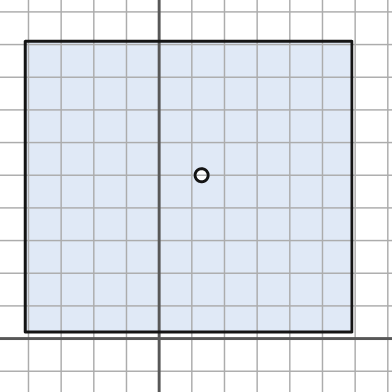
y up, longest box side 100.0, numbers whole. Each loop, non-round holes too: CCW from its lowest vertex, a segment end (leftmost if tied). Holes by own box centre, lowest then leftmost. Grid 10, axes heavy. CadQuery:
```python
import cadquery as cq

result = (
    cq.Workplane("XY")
    .moveTo(-41.0, 2.0)
    .lineTo(59.0, 2.0)
    .lineTo(59.0, 91.0)
    .lineTo(-41.0, 91.0)
    .close()
    .moveTo(13.0, 50.0)
    .circle(2.0)
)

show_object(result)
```